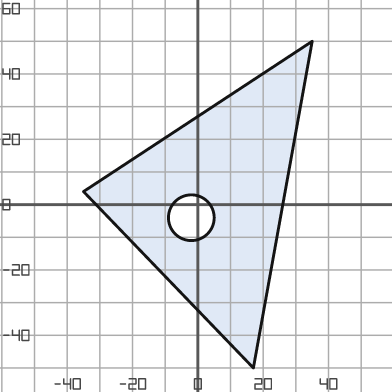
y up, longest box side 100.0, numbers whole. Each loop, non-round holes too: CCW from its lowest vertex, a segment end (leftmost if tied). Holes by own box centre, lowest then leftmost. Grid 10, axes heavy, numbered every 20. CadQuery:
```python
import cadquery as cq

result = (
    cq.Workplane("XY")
    .moveTo(17.0, -50.0)
    .lineTo(35.0, 50.0)
    .lineTo(-35.0, 4.0)
    .close()
    .moveTo(-2.0, -4.0)
    .circle(7.0)
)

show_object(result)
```